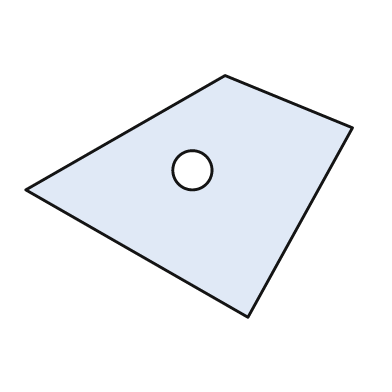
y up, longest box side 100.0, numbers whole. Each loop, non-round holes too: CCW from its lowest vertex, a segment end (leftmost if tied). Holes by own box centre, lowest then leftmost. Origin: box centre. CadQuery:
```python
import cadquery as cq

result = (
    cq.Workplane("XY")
    .moveTo(18.0, -37.0)
    .lineTo(50.0, 21.0)
    .lineTo(11.0, 37.0)
    .lineTo(-50.0, 2.0)
    .close()
    .moveTo(1.0, 8.0)
    .circle(6.0)
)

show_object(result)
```